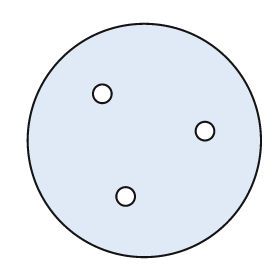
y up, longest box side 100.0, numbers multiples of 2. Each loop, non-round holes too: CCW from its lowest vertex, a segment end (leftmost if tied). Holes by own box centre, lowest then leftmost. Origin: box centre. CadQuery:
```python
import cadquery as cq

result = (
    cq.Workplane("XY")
    .moveTo(0.0, 0.0)
    .circle(50.0)
    .moveTo(-8.0, -24.0)
    .circle(4.0)
    .moveTo(26.0, 4.0)
    .circle(4.0)
    .moveTo(-18.0, 20.0)
    .circle(4.0)
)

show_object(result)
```